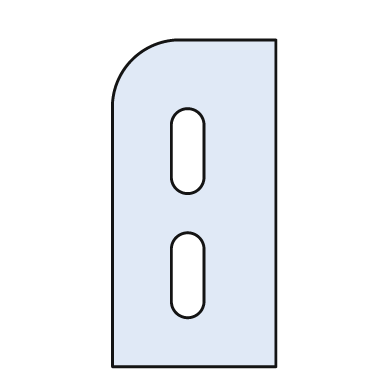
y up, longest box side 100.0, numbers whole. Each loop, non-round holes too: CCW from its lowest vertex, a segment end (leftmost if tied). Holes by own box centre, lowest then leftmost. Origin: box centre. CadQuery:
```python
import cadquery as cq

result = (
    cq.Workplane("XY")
    .moveTo(-25.0, -50.0)
    .lineTo(25.0, -50.0)
    .lineTo(25.0, 50.0)
    .lineTo(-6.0, 50.0)
    .threePointArc((-19.0, 44.0), (-25.0, 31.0))
    .close()
    .moveTo(-7.0, -30.0)
    .threePointArc((-2.0, -35.0), (3.0, -30.0))
    .lineTo(3.0, -14.0)
    .threePointArc((-2.0, -9.0), (-7.0, -14.0))
    .close()
    .moveTo(-7.0, 8.0)
    .threePointArc((-2.0, 3.0), (3.0, 8.0))
    .lineTo(3.0, 24.0)
    .threePointArc((-2.0, 29.0), (-7.0, 24.0))
    .close()
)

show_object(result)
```